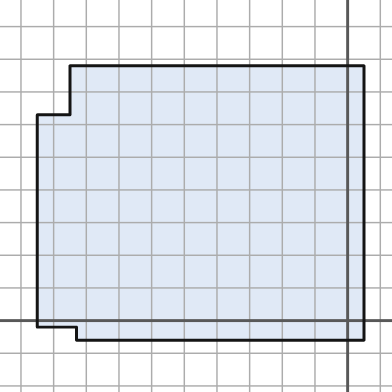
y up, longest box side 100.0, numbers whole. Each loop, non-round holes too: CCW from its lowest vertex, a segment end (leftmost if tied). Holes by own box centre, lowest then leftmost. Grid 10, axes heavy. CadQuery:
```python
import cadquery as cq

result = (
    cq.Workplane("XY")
    .moveTo(-83.0, -6.0)
    .lineTo(5.0, -6.0)
    .lineTo(5.0, 78.0)
    .lineTo(-85.0, 78.0)
    .lineTo(-85.0, 63.0)
    .lineTo(-95.0, 63.0)
    .lineTo(-95.0, -2.0)
    .lineTo(-83.0, -2.0)
    .close()
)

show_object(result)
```